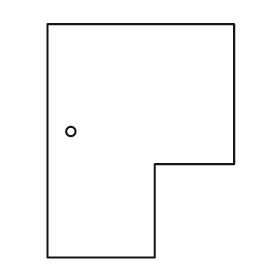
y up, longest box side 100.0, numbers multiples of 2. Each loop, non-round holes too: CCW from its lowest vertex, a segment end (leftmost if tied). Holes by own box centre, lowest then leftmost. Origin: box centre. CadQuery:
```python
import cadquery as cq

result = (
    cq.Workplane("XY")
    .moveTo(-40.0, -50.0)
    .lineTo(6.0, -50.0)
    .lineTo(6.0, -10.0)
    .lineTo(40.0, -10.0)
    .lineTo(40.0, 50.0)
    .lineTo(-40.0, 50.0)
    .close()
    .moveTo(-30.0, 4.0)
    .circle(2.0)
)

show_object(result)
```